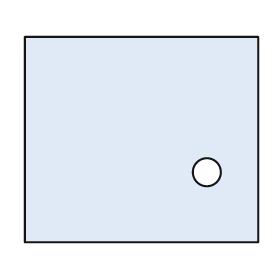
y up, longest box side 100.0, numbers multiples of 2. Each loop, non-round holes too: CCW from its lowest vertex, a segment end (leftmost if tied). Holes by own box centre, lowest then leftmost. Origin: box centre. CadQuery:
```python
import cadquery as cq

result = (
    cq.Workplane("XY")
    .moveTo(-50.0, -44.0)
    .lineTo(50.0, -44.0)
    .lineTo(50.0, 44.0)
    .lineTo(-50.0, 44.0)
    .close()
    .moveTo(28.0, -14.0)
    .circle(6.0)
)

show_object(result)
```